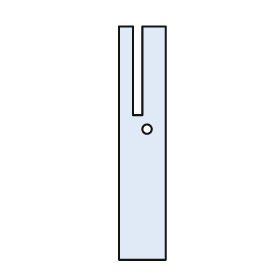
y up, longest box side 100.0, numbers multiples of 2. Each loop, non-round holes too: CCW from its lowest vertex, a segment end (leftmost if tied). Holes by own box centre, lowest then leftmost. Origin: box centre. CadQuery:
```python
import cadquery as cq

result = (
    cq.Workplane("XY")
    .moveTo(-10.0, -50.0)
    .lineTo(10.0, -50.0)
    .lineTo(10.0, 50.0)
    .lineTo(0.0, 50.0)
    .lineTo(0.0, 12.0)
    .lineTo(-4.0, 12.0)
    .lineTo(-4.0, 50.0)
    .lineTo(-10.0, 50.0)
    .close()
    .moveTo(2.0, 6.0)
    .circle(2.0)
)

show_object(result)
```